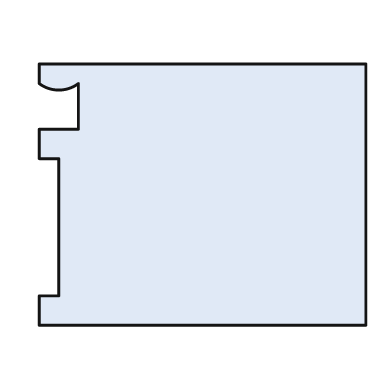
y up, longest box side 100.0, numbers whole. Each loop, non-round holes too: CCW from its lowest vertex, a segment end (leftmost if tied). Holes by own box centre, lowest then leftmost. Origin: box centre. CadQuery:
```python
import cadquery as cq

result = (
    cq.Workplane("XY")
    .moveTo(-50.0, -40.0)
    .lineTo(50.0, -40.0)
    .lineTo(50.0, 40.0)
    .lineTo(-50.0, 40.0)
    .lineTo(-50.0, 34.0)
    .threePointArc((-44.0, 32.0), (-38.0, 34.0))
    .lineTo(-38.0, 20.0)
    .lineTo(-50.0, 20.0)
    .lineTo(-50.0, 11.0)
    .lineTo(-44.0, 11.0)
    .lineTo(-44.0, -31.0)
    .lineTo(-50.0, -31.0)
    .close()
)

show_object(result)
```